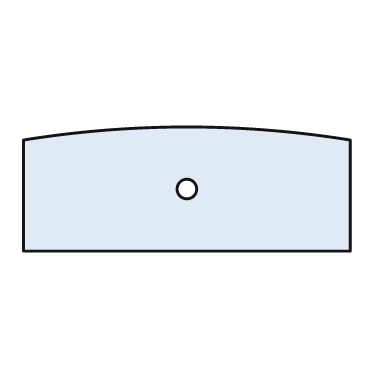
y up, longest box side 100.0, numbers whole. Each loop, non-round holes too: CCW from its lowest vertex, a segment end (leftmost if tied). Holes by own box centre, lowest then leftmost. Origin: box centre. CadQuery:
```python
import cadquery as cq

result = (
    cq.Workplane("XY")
    .moveTo(-50.0, -19.0)
    .lineTo(50.0, -19.0)
    .lineTo(50.0, 15.0)
    .threePointArc((0.0, 19.0), (-50.0, 15.0))
    .close()
    .moveTo(0.0, 0.0)
    .circle(3.0)
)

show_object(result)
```